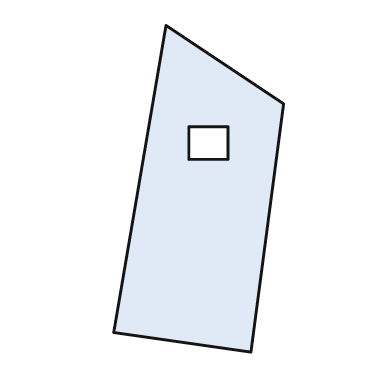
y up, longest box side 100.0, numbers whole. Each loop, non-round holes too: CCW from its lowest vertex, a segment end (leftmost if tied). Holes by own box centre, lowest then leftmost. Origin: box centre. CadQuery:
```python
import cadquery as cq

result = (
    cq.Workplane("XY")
    .moveTo(16.0, -50.0)
    .lineTo(26.0, 26.0)
    .lineTo(-10.0, 50.0)
    .lineTo(-26.0, -44.0)
    .close()
    .moveTo(-3.0, 9.0)
    .lineTo(9.0, 9.0)
    .lineTo(9.0, 19.0)
    .lineTo(-3.0, 19.0)
    .close()
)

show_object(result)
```